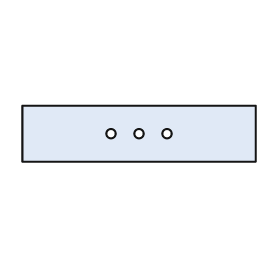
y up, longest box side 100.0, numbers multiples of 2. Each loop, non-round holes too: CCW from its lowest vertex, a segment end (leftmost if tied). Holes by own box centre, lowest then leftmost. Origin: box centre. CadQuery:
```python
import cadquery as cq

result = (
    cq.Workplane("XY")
    .moveTo(-50.0, -12.0)
    .lineTo(50.0, -12.0)
    .lineTo(50.0, 12.0)
    .lineTo(-50.0, 12.0)
    .close()
    .moveTo(-12.0, 0.0)
    .circle(2.0)
    .moveTo(0.0, 0.0)
    .circle(2.0)
    .moveTo(12.0, 0.0)
    .circle(2.0)
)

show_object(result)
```